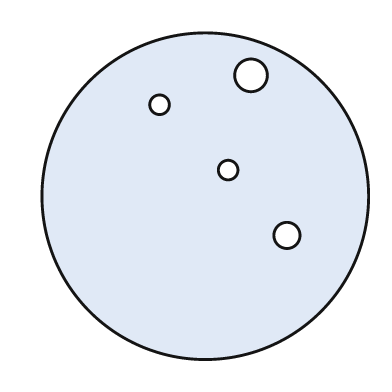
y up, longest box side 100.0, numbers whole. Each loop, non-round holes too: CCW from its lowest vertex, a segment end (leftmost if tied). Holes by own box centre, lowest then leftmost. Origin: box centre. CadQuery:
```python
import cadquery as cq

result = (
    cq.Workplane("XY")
    .moveTo(0.0, 0.0)
    .circle(50.0)
    .moveTo(25.0, -12.0)
    .circle(4.0)
    .moveTo(7.0, 8.0)
    .circle(3.0)
    .moveTo(-14.0, 28.0)
    .circle(3.0)
    .moveTo(14.0, 37.0)
    .circle(5.0)
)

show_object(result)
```